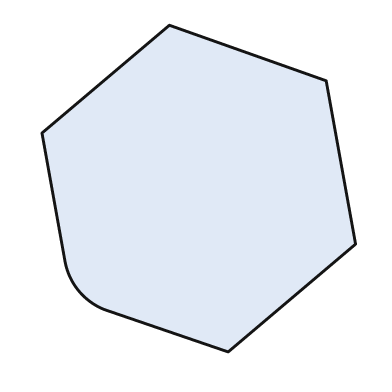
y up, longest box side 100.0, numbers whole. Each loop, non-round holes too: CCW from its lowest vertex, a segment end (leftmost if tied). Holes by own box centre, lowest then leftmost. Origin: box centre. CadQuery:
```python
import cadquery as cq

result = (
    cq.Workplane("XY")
    .moveTo(9.0, -50.0)
    .lineTo(48.0, -17.0)
    .lineTo(39.0, 33.0)
    .lineTo(-9.0, 50.0)
    .lineTo(-48.0, 17.0)
    .lineTo(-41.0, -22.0)
    .threePointArc((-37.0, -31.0), (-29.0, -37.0))
    .close()
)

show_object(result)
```